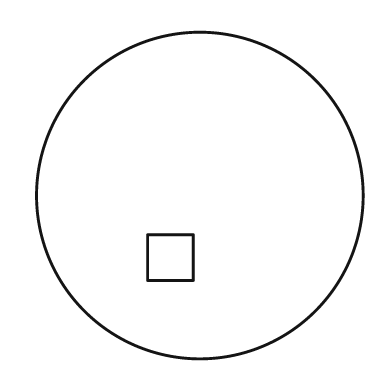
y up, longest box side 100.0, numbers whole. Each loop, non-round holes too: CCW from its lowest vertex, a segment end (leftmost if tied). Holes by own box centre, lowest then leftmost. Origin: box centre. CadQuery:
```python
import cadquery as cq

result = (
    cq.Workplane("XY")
    .moveTo(0.0, 0.0)
    .circle(50.0)
    .moveTo(-16.0, -26.0)
    .lineTo(-2.0, -26.0)
    .lineTo(-2.0, -12.0)
    .lineTo(-16.0, -12.0)
    .close()
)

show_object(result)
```